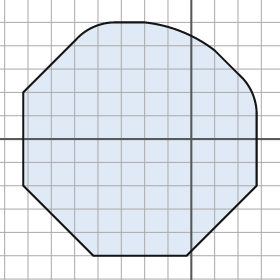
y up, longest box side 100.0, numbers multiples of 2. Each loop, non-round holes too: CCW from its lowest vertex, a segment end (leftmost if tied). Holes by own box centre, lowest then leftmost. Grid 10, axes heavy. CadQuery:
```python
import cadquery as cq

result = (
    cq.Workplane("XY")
    .moveTo(-42.0, -50.0)
    .lineTo(-2.0, -50.0)
    .lineTo(28.0, -20.0)
    .lineTo(28.0, 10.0)
    .threePointArc((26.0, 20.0), (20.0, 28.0))
    .lineTo(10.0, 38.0)
    .threePointArc((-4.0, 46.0), (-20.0, 50.0))
    .lineTo(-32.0, 50.0)
    .threePointArc((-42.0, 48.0), (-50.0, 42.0))
    .lineTo(-72.0, 20.0)
    .lineTo(-72.0, -20.0)
    .close()
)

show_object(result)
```